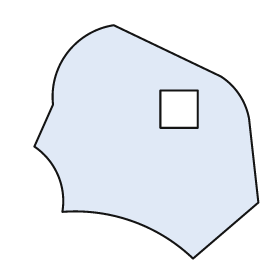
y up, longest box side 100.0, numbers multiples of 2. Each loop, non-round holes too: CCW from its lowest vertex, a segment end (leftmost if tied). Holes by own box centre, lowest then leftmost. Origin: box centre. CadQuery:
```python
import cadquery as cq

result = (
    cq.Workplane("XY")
    .moveTo(20.0, -50.0)
    .lineTo(48.0, -26.0)
    .lineTo(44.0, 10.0)
    .threePointArc((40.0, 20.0), (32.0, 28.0))
    .lineTo(-14.0, 50.0)
    .threePointArc((-34.0, 38.0), (-40.0, 16.0))
    .lineTo(-48.0, -2.0)
    .threePointArc((-38.0, -14.0), (-36.0, -30.0))
    .threePointArc((-6.0, -34.0), (20.0, -50.0))
    .close()
    .moveTo(6.0, 6.0)
    .lineTo(22.0, 6.0)
    .lineTo(22.0, 22.0)
    .lineTo(6.0, 22.0)
    .close()
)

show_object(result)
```